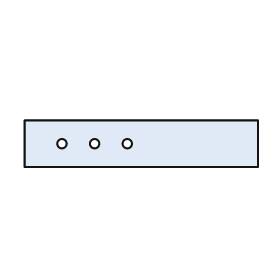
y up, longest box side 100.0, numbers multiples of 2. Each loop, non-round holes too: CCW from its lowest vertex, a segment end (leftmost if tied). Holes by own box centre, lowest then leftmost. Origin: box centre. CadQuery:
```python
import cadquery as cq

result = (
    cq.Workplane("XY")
    .moveTo(-50.0, -10.0)
    .lineTo(50.0, -10.0)
    .lineTo(50.0, 10.0)
    .lineTo(-50.0, 10.0)
    .close()
    .moveTo(-34.0, 0.0)
    .circle(2.0)
    .moveTo(-20.0, 0.0)
    .circle(2.0)
    .moveTo(-6.0, 0.0)
    .circle(2.0)
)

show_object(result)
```